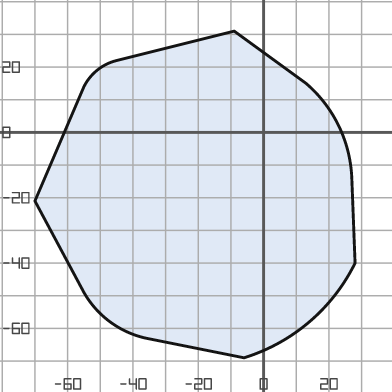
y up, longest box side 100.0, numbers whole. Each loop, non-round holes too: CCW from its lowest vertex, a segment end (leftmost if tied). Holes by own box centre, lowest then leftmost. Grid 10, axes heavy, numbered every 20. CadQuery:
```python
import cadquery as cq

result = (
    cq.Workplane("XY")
    .moveTo(-6.0, -69.0)
    .threePointArc((14.0, -58.0), (28.0, -40.0))
    .lineTo(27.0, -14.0)
    .threePointArc((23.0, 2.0), (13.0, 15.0))
    .lineTo(-9.0, 31.0)
    .lineTo(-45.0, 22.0)
    .threePointArc((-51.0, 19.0), (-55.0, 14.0))
    .lineTo(-70.0, -21.0)
    .lineTo(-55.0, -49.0)
    .threePointArc((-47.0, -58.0), (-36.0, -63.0))
    .close()
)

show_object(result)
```